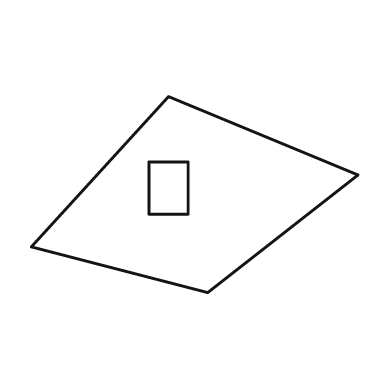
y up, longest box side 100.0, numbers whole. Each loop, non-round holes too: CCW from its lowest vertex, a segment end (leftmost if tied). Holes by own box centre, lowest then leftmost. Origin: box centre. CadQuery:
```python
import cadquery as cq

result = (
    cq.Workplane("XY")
    .moveTo(4.0, -30.0)
    .lineTo(50.0, 6.0)
    .lineTo(-8.0, 30.0)
    .lineTo(-50.0, -16.0)
    .close()
    .moveTo(-14.0, -6.0)
    .lineTo(-2.0, -6.0)
    .lineTo(-2.0, 10.0)
    .lineTo(-14.0, 10.0)
    .close()
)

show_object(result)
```